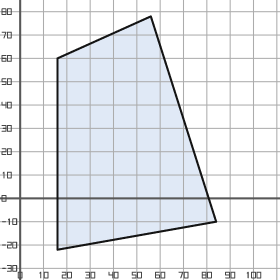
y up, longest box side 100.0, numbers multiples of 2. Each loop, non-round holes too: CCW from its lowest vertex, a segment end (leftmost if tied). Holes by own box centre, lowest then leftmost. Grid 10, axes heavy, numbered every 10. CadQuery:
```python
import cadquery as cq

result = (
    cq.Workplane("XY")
    .moveTo(16.0, -22.0)
    .lineTo(84.0, -10.0)
    .lineTo(56.0, 78.0)
    .lineTo(16.0, 60.0)
    .close()
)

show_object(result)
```